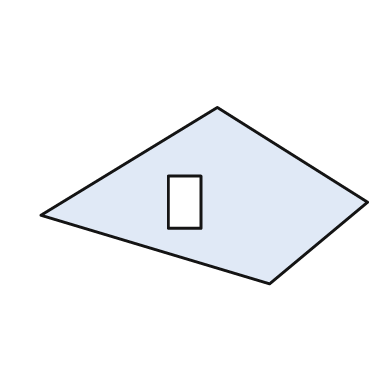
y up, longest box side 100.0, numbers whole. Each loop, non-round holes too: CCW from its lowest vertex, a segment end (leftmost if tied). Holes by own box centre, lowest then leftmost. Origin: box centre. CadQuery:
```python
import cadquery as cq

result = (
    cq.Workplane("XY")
    .moveTo(20.0, -27.0)
    .lineTo(50.0, -2.0)
    .lineTo(4.0, 27.0)
    .lineTo(-50.0, -6.0)
    .close()
    .moveTo(-11.0, -10.0)
    .lineTo(-1.0, -10.0)
    .lineTo(-1.0, 6.0)
    .lineTo(-11.0, 6.0)
    .close()
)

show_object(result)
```